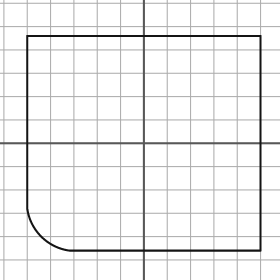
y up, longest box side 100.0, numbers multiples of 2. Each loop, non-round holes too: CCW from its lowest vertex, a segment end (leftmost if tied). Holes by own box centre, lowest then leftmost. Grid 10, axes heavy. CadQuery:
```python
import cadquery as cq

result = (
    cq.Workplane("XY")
    .moveTo(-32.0, -46.0)
    .lineTo(50.0, -46.0)
    .lineTo(50.0, 46.0)
    .lineTo(-50.0, 46.0)
    .lineTo(-50.0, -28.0)
    .threePointArc((-44.0, -40.0), (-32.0, -46.0))
    .close()
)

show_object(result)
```